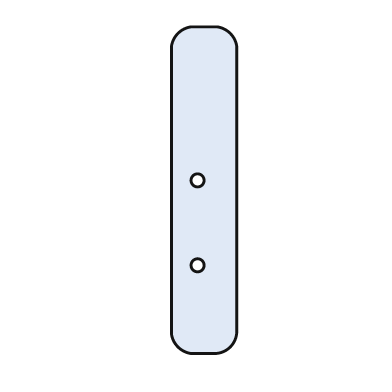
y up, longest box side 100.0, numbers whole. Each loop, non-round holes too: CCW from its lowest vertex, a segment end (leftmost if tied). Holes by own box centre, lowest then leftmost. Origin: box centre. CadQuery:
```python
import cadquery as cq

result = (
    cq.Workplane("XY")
    .moveTo(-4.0, -50.0)
    .lineTo(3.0, -50.0)
    .threePointArc((8.0, -48.0), (10.0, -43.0))
    .lineTo(10.0, 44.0)
    .threePointArc((8.0, 48.0), (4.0, 50.0))
    .lineTo(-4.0, 50.0)
    .threePointArc((-8.0, 48.0), (-10.0, 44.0))
    .lineTo(-10.0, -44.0)
    .threePointArc((-8.0, -48.0), (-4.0, -50.0))
    .close()
    .moveTo(-2.0, -23.0)
    .circle(2.0)
    .moveTo(-2.0, 3.0)
    .circle(2.0)
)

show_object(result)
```